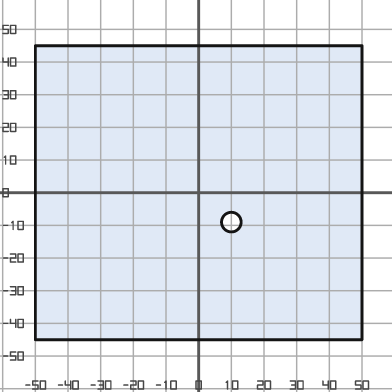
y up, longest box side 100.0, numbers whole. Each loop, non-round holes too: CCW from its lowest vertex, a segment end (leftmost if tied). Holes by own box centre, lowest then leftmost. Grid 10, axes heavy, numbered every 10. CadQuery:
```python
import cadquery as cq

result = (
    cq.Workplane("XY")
    .moveTo(-50.0, -45.0)
    .lineTo(50.0, -45.0)
    .lineTo(50.0, 45.0)
    .lineTo(-50.0, 45.0)
    .close()
    .moveTo(10.0, -9.0)
    .circle(3.0)
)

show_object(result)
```